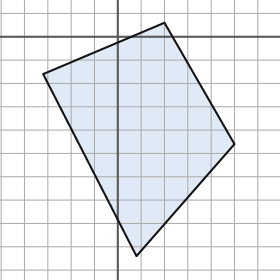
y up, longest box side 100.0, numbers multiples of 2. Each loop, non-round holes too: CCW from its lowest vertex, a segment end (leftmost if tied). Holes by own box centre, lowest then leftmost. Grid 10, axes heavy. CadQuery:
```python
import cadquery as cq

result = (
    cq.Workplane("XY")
    .moveTo(8.0, -94.0)
    .lineTo(50.0, -46.0)
    .lineTo(20.0, 6.0)
    .lineTo(-32.0, -16.0)
    .close()
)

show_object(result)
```